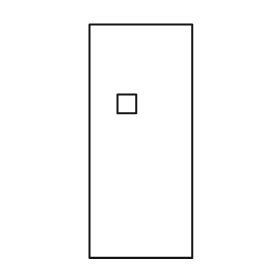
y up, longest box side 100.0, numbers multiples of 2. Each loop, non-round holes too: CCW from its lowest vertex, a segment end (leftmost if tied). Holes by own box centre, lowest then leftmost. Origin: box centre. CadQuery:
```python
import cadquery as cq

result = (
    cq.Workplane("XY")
    .moveTo(-22.0, -50.0)
    .lineTo(22.0, -50.0)
    .lineTo(22.0, 50.0)
    .lineTo(-22.0, 50.0)
    .close()
    .moveTo(-10.0, 12.0)
    .lineTo(-2.0, 12.0)
    .lineTo(-2.0, 20.0)
    .lineTo(-10.0, 20.0)
    .close()
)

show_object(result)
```